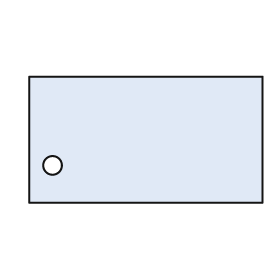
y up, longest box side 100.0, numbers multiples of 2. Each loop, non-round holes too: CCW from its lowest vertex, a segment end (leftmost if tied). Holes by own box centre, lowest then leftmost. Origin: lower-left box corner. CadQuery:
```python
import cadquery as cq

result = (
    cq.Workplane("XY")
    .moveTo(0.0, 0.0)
    .lineTo(100.0, 0.0)
    .lineTo(100.0, 54.0)
    .lineTo(0.0, 54.0)
    .close()
    .moveTo(10.0, 16.0)
    .circle(4.0)
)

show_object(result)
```